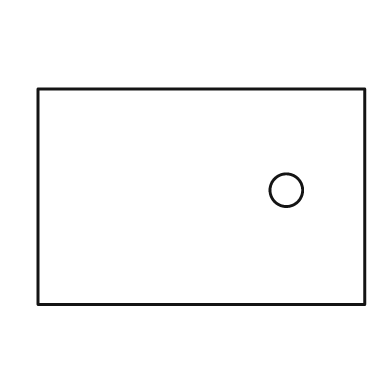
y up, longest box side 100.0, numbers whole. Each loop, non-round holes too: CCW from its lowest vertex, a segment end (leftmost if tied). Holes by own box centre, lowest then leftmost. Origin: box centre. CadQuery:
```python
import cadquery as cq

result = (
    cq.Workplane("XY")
    .moveTo(-50.0, -33.0)
    .lineTo(50.0, -33.0)
    .lineTo(50.0, 33.0)
    .lineTo(-50.0, 33.0)
    .close()
    .moveTo(26.0, 2.0)
    .circle(5.0)
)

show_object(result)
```